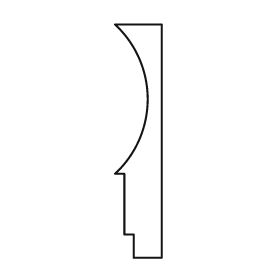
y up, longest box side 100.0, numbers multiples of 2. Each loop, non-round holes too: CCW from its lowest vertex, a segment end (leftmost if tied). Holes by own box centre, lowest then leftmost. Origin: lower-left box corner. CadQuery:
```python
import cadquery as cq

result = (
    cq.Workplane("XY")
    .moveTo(8.0, 0.0)
    .lineTo(20.0, 0.0)
    .lineTo(20.0, 100.0)
    .lineTo(0.0, 100.0)
    .threePointArc((14.0, 68.0), (0.0, 36.0))
    .lineTo(4.0, 36.0)
    .lineTo(4.0, 10.0)
    .lineTo(8.0, 10.0)
    .close()
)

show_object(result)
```